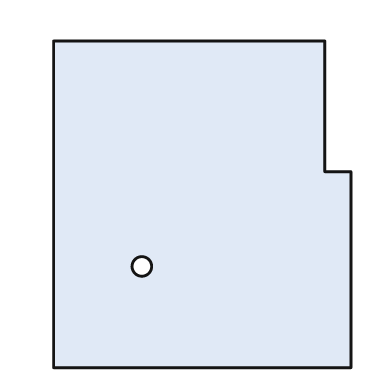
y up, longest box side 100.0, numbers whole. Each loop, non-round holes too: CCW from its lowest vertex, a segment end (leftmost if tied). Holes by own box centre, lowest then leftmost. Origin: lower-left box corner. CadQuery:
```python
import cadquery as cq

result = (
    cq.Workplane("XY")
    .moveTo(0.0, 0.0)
    .lineTo(91.0, 0.0)
    .lineTo(91.0, 60.0)
    .lineTo(83.0, 60.0)
    .lineTo(83.0, 100.0)
    .lineTo(0.0, 100.0)
    .close()
    .moveTo(27.0, 31.0)
    .circle(3.0)
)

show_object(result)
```